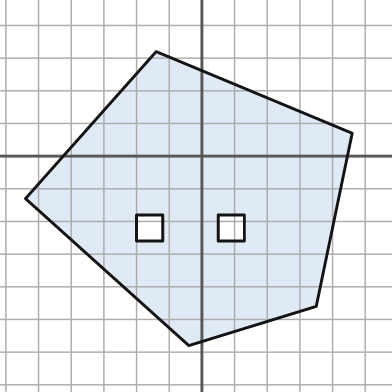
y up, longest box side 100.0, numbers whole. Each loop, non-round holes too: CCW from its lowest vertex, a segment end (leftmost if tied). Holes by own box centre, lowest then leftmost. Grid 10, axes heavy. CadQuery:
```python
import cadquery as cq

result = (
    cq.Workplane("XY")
    .moveTo(-4.0, -58.0)
    .lineTo(35.0, -46.0)
    .lineTo(46.0, 7.0)
    .lineTo(-14.0, 32.0)
    .lineTo(-54.0, -13.0)
    .close()
    .moveTo(-20.0, -26.0)
    .lineTo(-12.0, -26.0)
    .lineTo(-12.0, -18.0)
    .lineTo(-20.0, -18.0)
    .close()
    .moveTo(5.0, -26.0)
    .lineTo(13.0, -26.0)
    .lineTo(13.0, -18.0)
    .lineTo(5.0, -18.0)
    .close()
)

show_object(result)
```